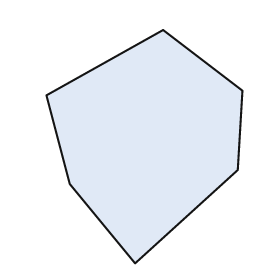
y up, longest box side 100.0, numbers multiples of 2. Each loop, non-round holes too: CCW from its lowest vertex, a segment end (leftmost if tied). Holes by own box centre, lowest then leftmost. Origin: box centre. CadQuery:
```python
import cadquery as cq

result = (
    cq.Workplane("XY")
    .moveTo(-4.0, -50.0)
    .lineTo(40.0, -10.0)
    .lineTo(42.0, 24.0)
    .lineTo(8.0, 50.0)
    .lineTo(-42.0, 22.0)
    .lineTo(-32.0, -16.0)
    .close()
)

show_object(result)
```